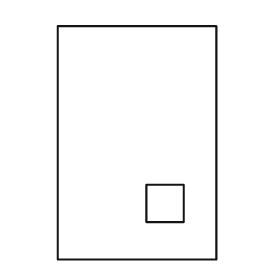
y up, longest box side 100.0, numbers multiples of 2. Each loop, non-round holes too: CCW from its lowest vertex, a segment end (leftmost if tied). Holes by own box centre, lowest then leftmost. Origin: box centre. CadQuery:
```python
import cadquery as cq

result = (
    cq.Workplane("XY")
    .moveTo(-34.0, -50.0)
    .lineTo(34.0, -50.0)
    .lineTo(34.0, 50.0)
    .lineTo(-34.0, 50.0)
    .close()
    .moveTo(4.0, -34.0)
    .lineTo(20.0, -34.0)
    .lineTo(20.0, -18.0)
    .lineTo(4.0, -18.0)
    .close()
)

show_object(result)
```